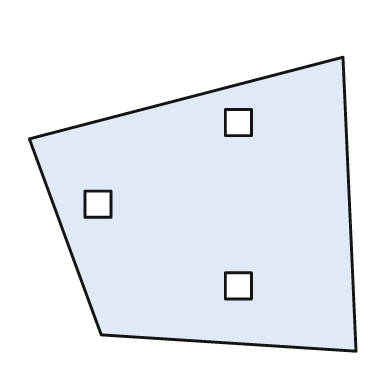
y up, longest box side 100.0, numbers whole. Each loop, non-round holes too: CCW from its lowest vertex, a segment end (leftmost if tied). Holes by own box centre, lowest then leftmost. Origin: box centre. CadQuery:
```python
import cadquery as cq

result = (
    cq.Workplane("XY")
    .moveTo(50.0, -45.0)
    .lineTo(46.0, 45.0)
    .lineTo(-50.0, 20.0)
    .lineTo(-28.0, -40.0)
    .close()
    .moveTo(10.0, -29.0)
    .lineTo(18.0, -29.0)
    .lineTo(18.0, -21.0)
    .lineTo(10.0, -21.0)
    .close()
    .moveTo(-33.0, -4.0)
    .lineTo(-25.0, -4.0)
    .lineTo(-25.0, 4.0)
    .lineTo(-33.0, 4.0)
    .close()
    .moveTo(10.0, 21.0)
    .lineTo(18.0, 21.0)
    .lineTo(18.0, 29.0)
    .lineTo(10.0, 29.0)
    .close()
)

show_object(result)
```